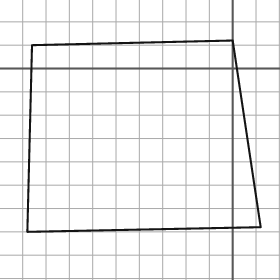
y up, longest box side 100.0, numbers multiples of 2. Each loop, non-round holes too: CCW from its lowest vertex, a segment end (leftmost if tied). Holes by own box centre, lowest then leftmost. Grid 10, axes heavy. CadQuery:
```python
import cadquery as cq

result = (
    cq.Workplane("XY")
    .moveTo(-88.0, -70.0)
    .lineTo(12.0, -68.0)
    .lineTo(0.0, 12.0)
    .lineTo(-86.0, 10.0)
    .close()
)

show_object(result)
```